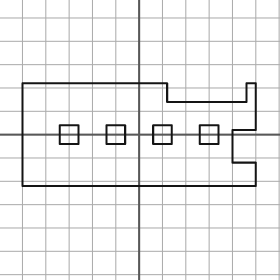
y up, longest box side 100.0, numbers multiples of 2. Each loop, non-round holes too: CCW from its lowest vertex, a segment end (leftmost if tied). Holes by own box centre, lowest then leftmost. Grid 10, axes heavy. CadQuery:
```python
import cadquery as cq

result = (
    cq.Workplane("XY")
    .moveTo(-50.0, -22.0)
    .lineTo(50.0, -22.0)
    .lineTo(50.0, -12.0)
    .lineTo(40.0, -12.0)
    .lineTo(40.0, 2.0)
    .lineTo(50.0, 2.0)
    .lineTo(50.0, 22.0)
    .lineTo(46.0, 22.0)
    .lineTo(46.0, 14.0)
    .lineTo(12.0, 14.0)
    .lineTo(12.0, 22.0)
    .lineTo(-50.0, 22.0)
    .close()
    .moveTo(-34.0, -4.0)
    .lineTo(-26.0, -4.0)
    .lineTo(-26.0, 4.0)
    .lineTo(-34.0, 4.0)
    .close()
    .moveTo(-14.0, -4.0)
    .lineTo(-6.0, -4.0)
    .lineTo(-6.0, 4.0)
    .lineTo(-14.0, 4.0)
    .close()
    .moveTo(6.0, -4.0)
    .lineTo(14.0, -4.0)
    .lineTo(14.0, 4.0)
    .lineTo(6.0, 4.0)
    .close()
    .moveTo(26.0, -4.0)
    .lineTo(34.0, -4.0)
    .lineTo(34.0, 4.0)
    .lineTo(26.0, 4.0)
    .close()
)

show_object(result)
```